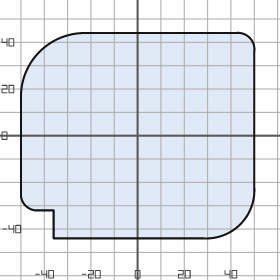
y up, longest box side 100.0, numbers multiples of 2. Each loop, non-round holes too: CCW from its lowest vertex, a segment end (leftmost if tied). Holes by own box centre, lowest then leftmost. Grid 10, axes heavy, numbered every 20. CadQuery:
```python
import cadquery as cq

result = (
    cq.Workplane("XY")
    .moveTo(-36.0, -44.0)
    .lineTo(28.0, -44.0)
    .threePointArc((44.0, -38.0), (50.0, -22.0))
    .lineTo(50.0, 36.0)
    .threePointArc((48.0, 42.0), (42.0, 44.0))
    .lineTo(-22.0, 44.0)
    .threePointArc((-42.0, 36.0), (-50.0, 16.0))
    .lineTo(-50.0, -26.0)
    .threePointArc((-48.0, -30.0), (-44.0, -32.0))
    .lineTo(-36.0, -32.0)
    .close()
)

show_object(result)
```